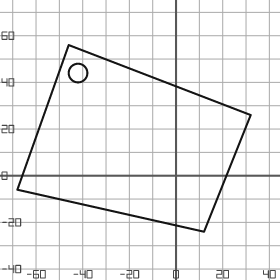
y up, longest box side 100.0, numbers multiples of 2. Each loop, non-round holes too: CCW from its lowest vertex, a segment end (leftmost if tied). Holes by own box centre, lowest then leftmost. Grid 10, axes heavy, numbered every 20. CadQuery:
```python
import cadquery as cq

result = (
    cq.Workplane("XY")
    .moveTo(12.0, -24.0)
    .lineTo(32.0, 26.0)
    .lineTo(-46.0, 56.0)
    .lineTo(-68.0, -6.0)
    .close()
    .moveTo(-42.0, 44.0)
    .circle(4.0)
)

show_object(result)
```